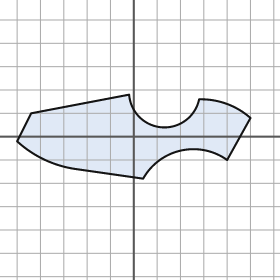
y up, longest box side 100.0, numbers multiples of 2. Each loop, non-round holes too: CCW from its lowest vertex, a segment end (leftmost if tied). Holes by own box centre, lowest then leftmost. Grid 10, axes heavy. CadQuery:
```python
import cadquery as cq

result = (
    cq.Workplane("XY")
    .moveTo(4.0, -18.0)
    .threePointArc((20.0, -6.0), (40.0, -10.0))
    .lineTo(50.0, 8.0)
    .threePointArc((40.0, 14.0), (28.0, 16.0))
    .threePointArc((12.0, 4.0), (-2.0, 18.0))
    .lineTo(-44.0, 10.0)
    .lineTo(-50.0, -2.0)
    .threePointArc((-38.0, -10.0), (-24.0, -14.0))
    .close()
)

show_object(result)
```